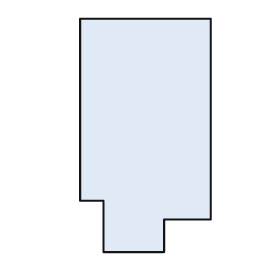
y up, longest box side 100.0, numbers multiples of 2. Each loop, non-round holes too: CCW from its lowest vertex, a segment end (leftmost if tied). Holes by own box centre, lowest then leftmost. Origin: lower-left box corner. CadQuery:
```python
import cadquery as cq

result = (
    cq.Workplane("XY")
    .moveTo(10.0, 0.0)
    .lineTo(36.0, 0.0)
    .lineTo(36.0, 14.0)
    .lineTo(56.0, 14.0)
    .lineTo(56.0, 100.0)
    .lineTo(0.0, 100.0)
    .lineTo(0.0, 22.0)
    .lineTo(10.0, 22.0)
    .close()
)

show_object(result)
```